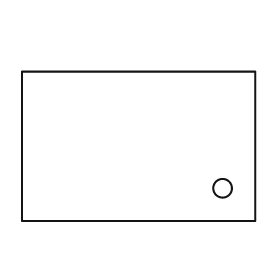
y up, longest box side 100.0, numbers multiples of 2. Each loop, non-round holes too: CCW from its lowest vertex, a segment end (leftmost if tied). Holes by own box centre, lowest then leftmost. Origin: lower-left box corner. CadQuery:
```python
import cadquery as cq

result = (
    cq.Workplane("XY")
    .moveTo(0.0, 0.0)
    .lineTo(100.0, 0.0)
    .lineTo(100.0, 64.0)
    .lineTo(0.0, 64.0)
    .close()
    .moveTo(86.0, 14.0)
    .circle(4.0)
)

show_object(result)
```